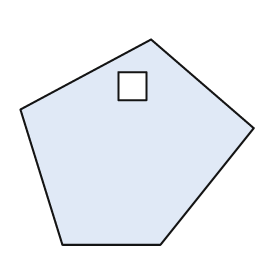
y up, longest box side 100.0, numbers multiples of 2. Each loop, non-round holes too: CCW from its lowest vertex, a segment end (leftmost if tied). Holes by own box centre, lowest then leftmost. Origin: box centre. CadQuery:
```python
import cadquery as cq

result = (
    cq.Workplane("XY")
    .moveTo(-32.0, -44.0)
    .lineTo(10.0, -44.0)
    .lineTo(50.0, 6.0)
    .lineTo(6.0, 44.0)
    .lineTo(-50.0, 14.0)
    .close()
    .moveTo(-8.0, 18.0)
    .lineTo(4.0, 18.0)
    .lineTo(4.0, 30.0)
    .lineTo(-8.0, 30.0)
    .close()
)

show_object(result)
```